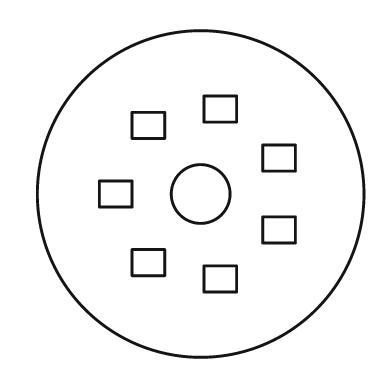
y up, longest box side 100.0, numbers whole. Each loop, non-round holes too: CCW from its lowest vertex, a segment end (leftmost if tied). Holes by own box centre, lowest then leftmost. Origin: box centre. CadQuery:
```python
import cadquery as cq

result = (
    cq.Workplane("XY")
    .moveTo(0.0, 0.0)
    .circle(50.0)
    .moveTo(1.0, -30.0)
    .lineTo(11.0, -30.0)
    .lineTo(11.0, -22.0)
    .lineTo(1.0, -22.0)
    .close()
    .moveTo(-21.0, -25.0)
    .lineTo(-11.0, -25.0)
    .lineTo(-11.0, -17.0)
    .lineTo(-21.0, -17.0)
    .close()
    .moveTo(19.0, -15.0)
    .lineTo(29.0, -15.0)
    .lineTo(29.0, -7.0)
    .lineTo(19.0, -7.0)
    .close()
    .moveTo(-31.0, -4.0)
    .lineTo(-21.0, -4.0)
    .lineTo(-21.0, 4.0)
    .lineTo(-31.0, 4.0)
    .close()
    .moveTo(0.0, 0.0)
    .circle(9.0)
    .moveTo(19.0, 7.0)
    .lineTo(29.0, 7.0)
    .lineTo(29.0, 15.0)
    .lineTo(19.0, 15.0)
    .close()
    .moveTo(-21.0, 17.0)
    .lineTo(-11.0, 17.0)
    .lineTo(-11.0, 25.0)
    .lineTo(-21.0, 25.0)
    .close()
    .moveTo(1.0, 22.0)
    .lineTo(11.0, 22.0)
    .lineTo(11.0, 30.0)
    .lineTo(1.0, 30.0)
    .close()
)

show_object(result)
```